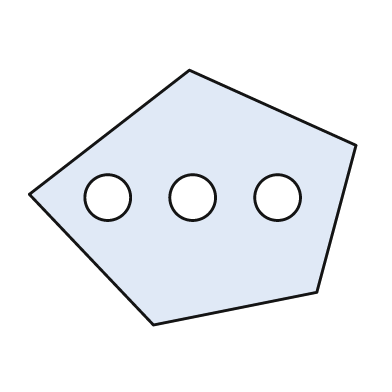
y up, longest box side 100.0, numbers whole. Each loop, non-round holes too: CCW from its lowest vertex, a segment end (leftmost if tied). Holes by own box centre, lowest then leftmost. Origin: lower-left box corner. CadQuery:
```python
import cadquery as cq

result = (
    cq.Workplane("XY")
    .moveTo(38.0, 0.0)
    .lineTo(88.0, 10.0)
    .lineTo(100.0, 55.0)
    .lineTo(49.0, 78.0)
    .lineTo(0.0, 40.0)
    .close()
    .moveTo(24.0, 39.0)
    .circle(7.0)
    .moveTo(50.0, 39.0)
    .circle(7.0)
    .moveTo(76.0, 39.0)
    .circle(7.0)
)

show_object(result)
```